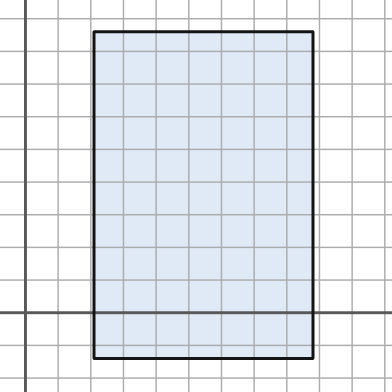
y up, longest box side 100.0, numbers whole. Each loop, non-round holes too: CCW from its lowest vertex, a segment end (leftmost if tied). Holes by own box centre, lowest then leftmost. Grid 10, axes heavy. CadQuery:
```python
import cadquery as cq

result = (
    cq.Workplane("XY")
    .moveTo(21.0, -14.0)
    .lineTo(88.0, -14.0)
    .lineTo(88.0, 86.0)
    .lineTo(21.0, 86.0)
    .close()
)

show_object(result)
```